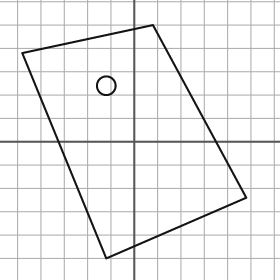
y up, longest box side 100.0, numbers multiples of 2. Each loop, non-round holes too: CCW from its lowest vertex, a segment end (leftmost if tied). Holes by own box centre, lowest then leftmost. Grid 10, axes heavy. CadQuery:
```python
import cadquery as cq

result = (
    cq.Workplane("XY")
    .moveTo(-12.0, -50.0)
    .lineTo(48.0, -24.0)
    .lineTo(8.0, 50.0)
    .lineTo(-48.0, 38.0)
    .close()
    .moveTo(-12.0, 24.0)
    .circle(4.0)
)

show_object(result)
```